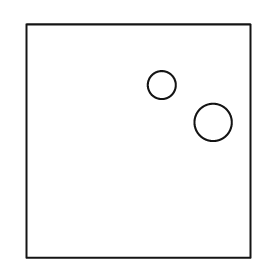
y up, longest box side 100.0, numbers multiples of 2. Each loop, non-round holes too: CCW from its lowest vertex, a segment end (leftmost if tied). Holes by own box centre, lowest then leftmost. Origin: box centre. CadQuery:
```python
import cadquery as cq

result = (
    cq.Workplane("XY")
    .moveTo(-48.0, -50.0)
    .lineTo(48.0, -50.0)
    .lineTo(48.0, 50.0)
    .lineTo(-48.0, 50.0)
    .close()
    .moveTo(32.0, 8.0)
    .circle(8.0)
    .moveTo(10.0, 24.0)
    .circle(6.0)
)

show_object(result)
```